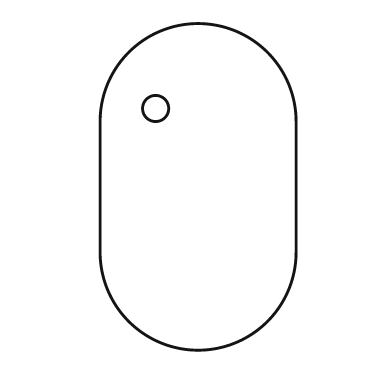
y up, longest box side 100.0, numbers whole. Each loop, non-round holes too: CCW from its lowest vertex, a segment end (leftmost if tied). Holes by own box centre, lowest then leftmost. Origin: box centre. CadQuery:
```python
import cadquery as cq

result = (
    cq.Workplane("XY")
    .moveTo(-30.0, -20.0)
    .threePointArc((0.0, -50.0), (30.0, -20.0))
    .lineTo(30.0, 20.0)
    .threePointArc((0.0, 50.0), (-30.0, 20.0))
    .close()
    .moveTo(-13.0, 24.0)
    .circle(4.0)
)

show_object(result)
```